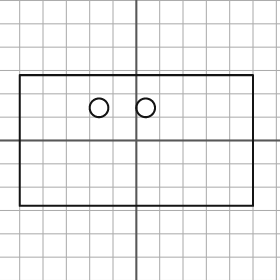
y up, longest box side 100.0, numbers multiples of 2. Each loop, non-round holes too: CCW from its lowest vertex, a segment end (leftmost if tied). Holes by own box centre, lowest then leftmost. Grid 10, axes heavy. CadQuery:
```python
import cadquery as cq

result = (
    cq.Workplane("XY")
    .moveTo(-50.0, -28.0)
    .lineTo(50.0, -28.0)
    .lineTo(50.0, 28.0)
    .lineTo(-50.0, 28.0)
    .close()
    .moveTo(-16.0, 14.0)
    .circle(4.0)
    .moveTo(4.0, 14.0)
    .circle(4.0)
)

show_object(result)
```